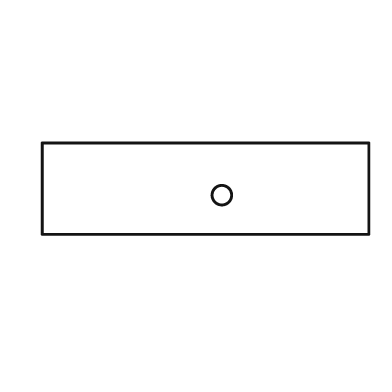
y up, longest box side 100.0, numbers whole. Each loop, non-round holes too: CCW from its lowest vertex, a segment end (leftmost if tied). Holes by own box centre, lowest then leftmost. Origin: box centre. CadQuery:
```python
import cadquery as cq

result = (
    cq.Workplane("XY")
    .moveTo(-50.0, -14.0)
    .lineTo(50.0, -14.0)
    .lineTo(50.0, 14.0)
    .lineTo(-50.0, 14.0)
    .close()
    .moveTo(5.0, -2.0)
    .circle(3.0)
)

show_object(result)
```